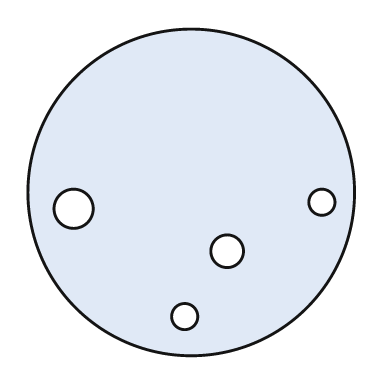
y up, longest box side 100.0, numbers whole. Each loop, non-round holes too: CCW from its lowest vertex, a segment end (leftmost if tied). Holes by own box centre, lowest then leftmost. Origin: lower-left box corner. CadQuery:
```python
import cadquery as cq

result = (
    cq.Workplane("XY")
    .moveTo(50.0, 50.0)
    .circle(50.0)
    .moveTo(48.0, 12.0)
    .circle(4.0)
    .moveTo(61.0, 32.0)
    .circle(5.0)
    .moveTo(14.0, 45.0)
    .circle(6.0)
    .moveTo(90.0, 47.0)
    .circle(4.0)
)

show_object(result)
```